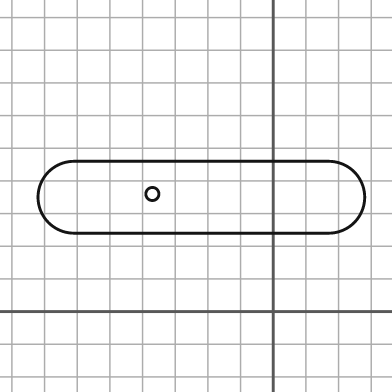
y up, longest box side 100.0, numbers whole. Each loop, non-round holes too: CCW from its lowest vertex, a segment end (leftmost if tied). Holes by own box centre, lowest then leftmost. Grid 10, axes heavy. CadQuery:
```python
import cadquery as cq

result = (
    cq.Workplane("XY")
    .moveTo(-61.0, 24.0)
    .lineTo(17.0, 24.0)
    .threePointArc((28.0, 35.0), (17.0, 46.0))
    .lineTo(-61.0, 46.0)
    .threePointArc((-72.0, 35.0), (-61.0, 24.0))
    .close()
    .moveTo(-37.0, 36.0)
    .circle(2.0)
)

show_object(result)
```